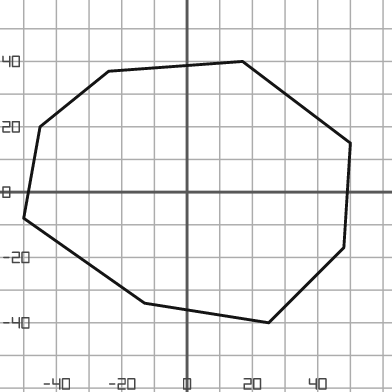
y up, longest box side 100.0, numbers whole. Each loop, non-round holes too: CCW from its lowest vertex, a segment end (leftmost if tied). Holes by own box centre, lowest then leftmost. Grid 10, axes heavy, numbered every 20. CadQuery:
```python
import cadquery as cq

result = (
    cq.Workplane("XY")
    .moveTo(25.0, -40.0)
    .lineTo(48.0, -17.0)
    .lineTo(50.0, 15.0)
    .lineTo(17.0, 40.0)
    .lineTo(-24.0, 37.0)
    .lineTo(-45.0, 20.0)
    .lineTo(-50.0, -8.0)
    .lineTo(-13.0, -34.0)
    .close()
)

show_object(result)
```